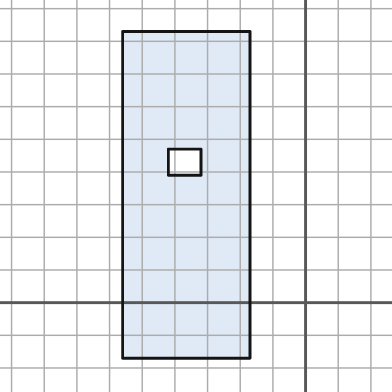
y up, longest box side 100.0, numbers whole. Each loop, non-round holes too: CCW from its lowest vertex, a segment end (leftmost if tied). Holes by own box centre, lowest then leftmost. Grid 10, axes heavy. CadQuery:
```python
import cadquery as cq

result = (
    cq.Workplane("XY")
    .moveTo(-56.0, -17.0)
    .lineTo(-17.0, -17.0)
    .lineTo(-17.0, 83.0)
    .lineTo(-56.0, 83.0)
    .close()
    .moveTo(-42.0, 39.0)
    .lineTo(-32.0, 39.0)
    .lineTo(-32.0, 47.0)
    .lineTo(-42.0, 47.0)
    .close()
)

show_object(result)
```